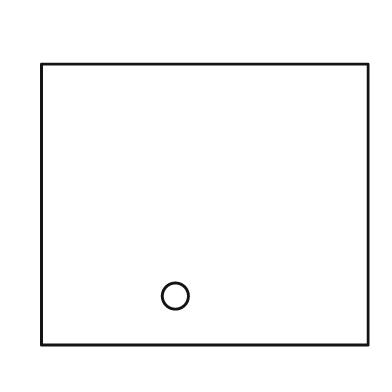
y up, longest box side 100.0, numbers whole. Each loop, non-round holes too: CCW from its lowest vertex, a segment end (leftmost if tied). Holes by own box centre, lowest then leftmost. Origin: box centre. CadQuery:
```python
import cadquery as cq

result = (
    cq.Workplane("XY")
    .moveTo(-50.0, -43.0)
    .lineTo(50.0, -43.0)
    .lineTo(50.0, 43.0)
    .lineTo(-50.0, 43.0)
    .close()
    .moveTo(-9.0, -28.0)
    .circle(4.0)
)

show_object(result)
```